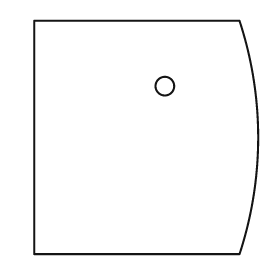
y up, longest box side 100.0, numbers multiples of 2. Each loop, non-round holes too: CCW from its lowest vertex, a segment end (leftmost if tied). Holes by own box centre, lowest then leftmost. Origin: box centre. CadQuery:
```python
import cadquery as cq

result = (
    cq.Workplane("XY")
    .moveTo(-48.0, -50.0)
    .lineTo(40.0, -50.0)
    .threePointArc((48.0, 0.0), (40.0, 50.0))
    .lineTo(-48.0, 50.0)
    .close()
    .moveTo(8.0, 22.0)
    .circle(4.0)
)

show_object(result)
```